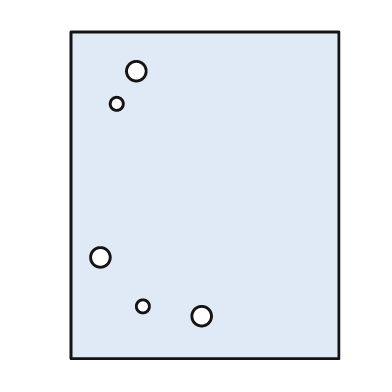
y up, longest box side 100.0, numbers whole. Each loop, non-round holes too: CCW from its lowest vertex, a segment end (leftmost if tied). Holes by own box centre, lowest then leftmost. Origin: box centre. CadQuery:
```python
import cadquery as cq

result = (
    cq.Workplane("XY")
    .moveTo(-41.0, -50.0)
    .lineTo(41.0, -50.0)
    .lineTo(41.0, 50.0)
    .lineTo(-41.0, 50.0)
    .close()
    .moveTo(-1.0, -37.0)
    .circle(3.0)
    .moveTo(-19.0, -34.0)
    .circle(2.0)
    .moveTo(-32.0, -19.0)
    .circle(3.0)
    .moveTo(-27.0, 28.0)
    .circle(2.0)
    .moveTo(-21.0, 38.0)
    .circle(3.0)
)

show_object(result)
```